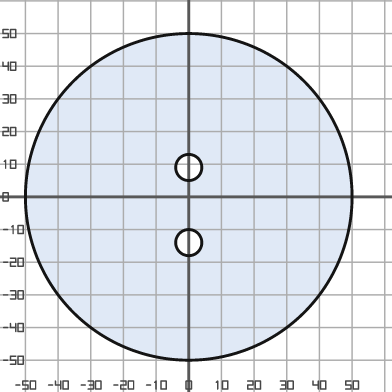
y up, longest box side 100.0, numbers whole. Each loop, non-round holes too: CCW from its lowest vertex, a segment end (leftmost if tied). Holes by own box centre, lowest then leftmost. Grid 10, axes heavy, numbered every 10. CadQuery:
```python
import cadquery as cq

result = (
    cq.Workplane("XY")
    .moveTo(0.0, 0.0)
    .circle(50.0)
    .moveTo(0.0, -14.0)
    .circle(4.0)
    .moveTo(0.0, 9.0)
    .circle(4.0)
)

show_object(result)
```